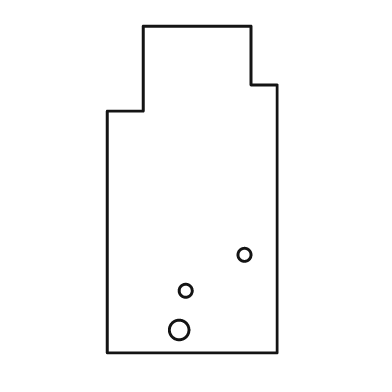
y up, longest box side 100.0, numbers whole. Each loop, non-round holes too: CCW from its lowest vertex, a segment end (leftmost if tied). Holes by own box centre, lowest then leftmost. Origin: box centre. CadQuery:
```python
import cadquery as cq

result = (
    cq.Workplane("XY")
    .moveTo(-26.0, -50.0)
    .lineTo(26.0, -50.0)
    .lineTo(26.0, 32.0)
    .lineTo(18.0, 32.0)
    .lineTo(18.0, 50.0)
    .lineTo(-15.0, 50.0)
    .lineTo(-15.0, 24.0)
    .lineTo(-26.0, 24.0)
    .close()
    .moveTo(-4.0, -43.0)
    .circle(3.0)
    .moveTo(-2.0, -31.0)
    .circle(2.0)
    .moveTo(16.0, -20.0)
    .circle(2.0)
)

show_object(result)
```